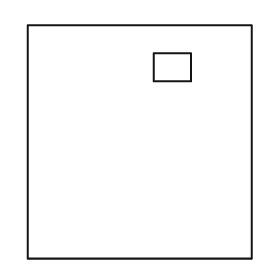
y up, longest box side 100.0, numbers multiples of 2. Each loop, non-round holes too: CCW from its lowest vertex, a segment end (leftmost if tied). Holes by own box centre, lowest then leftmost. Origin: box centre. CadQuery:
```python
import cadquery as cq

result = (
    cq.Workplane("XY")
    .moveTo(-48.0, -50.0)
    .lineTo(48.0, -50.0)
    .lineTo(48.0, 50.0)
    .lineTo(-48.0, 50.0)
    .close()
    .moveTo(6.0, 26.0)
    .lineTo(22.0, 26.0)
    .lineTo(22.0, 38.0)
    .lineTo(6.0, 38.0)
    .close()
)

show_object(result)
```